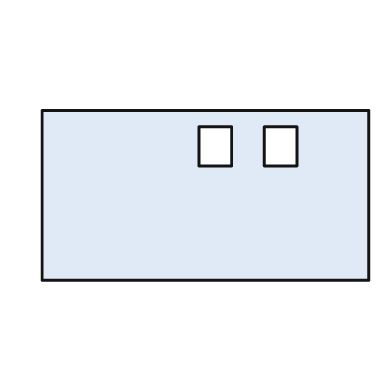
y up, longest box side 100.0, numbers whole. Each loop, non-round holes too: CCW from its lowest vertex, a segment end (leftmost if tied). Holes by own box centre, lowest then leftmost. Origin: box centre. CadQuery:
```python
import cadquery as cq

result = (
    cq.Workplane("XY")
    .moveTo(-50.0, -26.0)
    .lineTo(50.0, -26.0)
    .lineTo(50.0, 26.0)
    .lineTo(-50.0, 26.0)
    .close()
    .moveTo(-2.0, 9.0)
    .lineTo(8.0, 9.0)
    .lineTo(8.0, 21.0)
    .lineTo(-2.0, 21.0)
    .close()
    .moveTo(18.0, 9.0)
    .lineTo(28.0, 9.0)
    .lineTo(28.0, 21.0)
    .lineTo(18.0, 21.0)
    .close()
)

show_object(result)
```